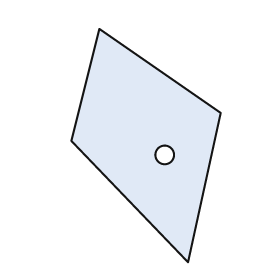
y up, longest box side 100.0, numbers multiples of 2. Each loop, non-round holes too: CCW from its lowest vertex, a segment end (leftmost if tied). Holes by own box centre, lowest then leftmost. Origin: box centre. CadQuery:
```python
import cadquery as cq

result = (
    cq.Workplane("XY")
    .moveTo(18.0, -50.0)
    .lineTo(32.0, 14.0)
    .lineTo(-20.0, 50.0)
    .lineTo(-32.0, 2.0)
    .close()
    .moveTo(8.0, -4.0)
    .circle(4.0)
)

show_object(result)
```